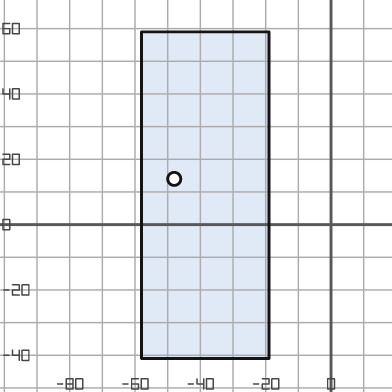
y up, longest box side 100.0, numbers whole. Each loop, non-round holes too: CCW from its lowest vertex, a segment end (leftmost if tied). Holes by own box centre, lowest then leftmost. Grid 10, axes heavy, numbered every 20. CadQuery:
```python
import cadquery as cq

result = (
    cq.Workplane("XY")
    .moveTo(-58.0, -41.0)
    .lineTo(-19.0, -41.0)
    .lineTo(-19.0, 59.0)
    .lineTo(-58.0, 59.0)
    .close()
    .moveTo(-48.0, 14.0)
    .circle(2.0)
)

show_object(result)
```